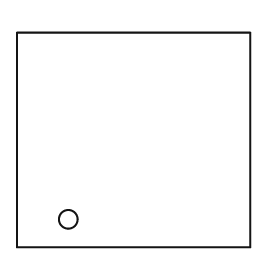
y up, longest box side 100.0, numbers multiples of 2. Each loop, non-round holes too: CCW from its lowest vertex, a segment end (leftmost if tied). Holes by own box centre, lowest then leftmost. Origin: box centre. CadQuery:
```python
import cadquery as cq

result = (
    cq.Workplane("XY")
    .moveTo(-50.0, -46.0)
    .lineTo(50.0, -46.0)
    .lineTo(50.0, 46.0)
    .lineTo(-50.0, 46.0)
    .close()
    .moveTo(-28.0, -34.0)
    .circle(4.0)
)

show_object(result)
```